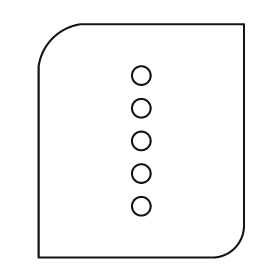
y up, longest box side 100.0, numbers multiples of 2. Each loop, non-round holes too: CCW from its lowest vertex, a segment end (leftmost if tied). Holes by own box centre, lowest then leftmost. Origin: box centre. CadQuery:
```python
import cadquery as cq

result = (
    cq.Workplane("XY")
    .moveTo(-44.0, -50.0)
    .lineTo(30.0, -50.0)
    .threePointArc((40.0, -46.0), (44.0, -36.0))
    .lineTo(44.0, 50.0)
    .lineTo(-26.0, 50.0)
    .threePointArc((-38.0, 44.0), (-44.0, 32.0))
    .close()
    .moveTo(0.0, -28.0)
    .circle(4.0)
    .moveTo(0.0, -14.0)
    .circle(4.0)
    .moveTo(0.0, 0.0)
    .circle(4.0)
    .moveTo(0.0, 14.0)
    .circle(4.0)
    .moveTo(0.0, 28.0)
    .circle(4.0)
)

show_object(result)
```